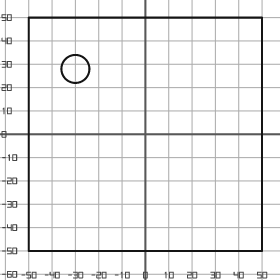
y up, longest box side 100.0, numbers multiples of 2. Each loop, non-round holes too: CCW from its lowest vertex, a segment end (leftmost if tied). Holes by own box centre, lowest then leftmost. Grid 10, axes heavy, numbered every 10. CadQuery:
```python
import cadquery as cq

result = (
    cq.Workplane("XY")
    .moveTo(-50.0, -50.0)
    .lineTo(50.0, -50.0)
    .lineTo(50.0, 50.0)
    .lineTo(-50.0, 50.0)
    .close()
    .moveTo(-30.0, 28.0)
    .circle(6.0)
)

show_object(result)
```